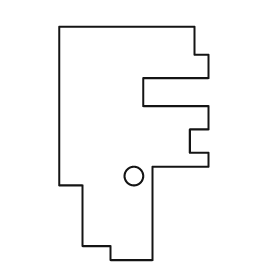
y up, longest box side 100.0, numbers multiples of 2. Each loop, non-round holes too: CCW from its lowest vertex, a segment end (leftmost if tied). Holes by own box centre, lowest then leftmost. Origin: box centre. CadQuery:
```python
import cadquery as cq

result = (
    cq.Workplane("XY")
    .moveTo(-10.0, -50.0)
    .lineTo(8.0, -50.0)
    .lineTo(8.0, -10.0)
    .lineTo(32.0, -10.0)
    .lineTo(32.0, -4.0)
    .lineTo(24.0, -4.0)
    .lineTo(24.0, 6.0)
    .lineTo(32.0, 6.0)
    .lineTo(32.0, 16.0)
    .lineTo(4.0, 16.0)
    .lineTo(4.0, 28.0)
    .lineTo(32.0, 28.0)
    .lineTo(32.0, 38.0)
    .lineTo(26.0, 38.0)
    .lineTo(26.0, 50.0)
    .lineTo(-32.0, 50.0)
    .lineTo(-32.0, -18.0)
    .lineTo(-22.0, -18.0)
    .lineTo(-22.0, -44.0)
    .lineTo(-10.0, -44.0)
    .close()
    .moveTo(0.0, -14.0)
    .circle(4.0)
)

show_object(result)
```